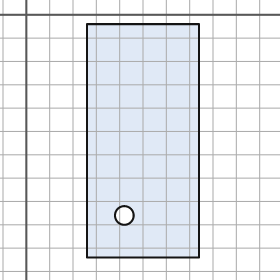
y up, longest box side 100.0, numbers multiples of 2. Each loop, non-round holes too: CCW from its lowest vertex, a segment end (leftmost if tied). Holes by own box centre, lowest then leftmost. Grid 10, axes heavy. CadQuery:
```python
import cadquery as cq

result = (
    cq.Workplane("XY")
    .moveTo(26.0, -104.0)
    .lineTo(74.0, -104.0)
    .lineTo(74.0, -4.0)
    .lineTo(26.0, -4.0)
    .close()
    .moveTo(42.0, -86.0)
    .circle(4.0)
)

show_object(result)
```